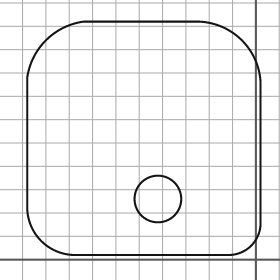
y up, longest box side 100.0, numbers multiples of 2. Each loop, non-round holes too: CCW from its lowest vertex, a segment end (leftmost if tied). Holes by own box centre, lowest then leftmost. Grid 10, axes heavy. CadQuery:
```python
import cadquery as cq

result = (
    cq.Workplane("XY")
    .moveTo(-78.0, 2.0)
    .lineTo(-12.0, 2.0)
    .threePointArc((-2.0, 6.0), (2.0, 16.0))
    .lineTo(2.0, 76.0)
    .threePointArc((-6.0, 94.0), (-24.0, 102.0))
    .lineTo(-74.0, 102.0)
    .threePointArc((-90.0, 94.0), (-98.0, 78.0))
    .lineTo(-98.0, 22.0)
    .threePointArc((-92.0, 8.0), (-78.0, 2.0))
    .close()
    .moveTo(-42.0, 26.0)
    .circle(10.0)
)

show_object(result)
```